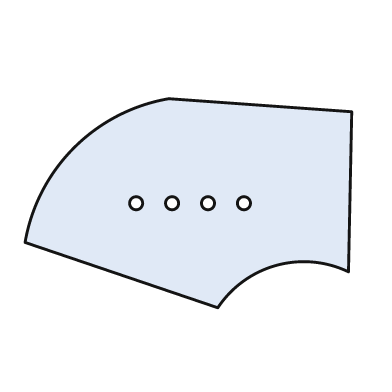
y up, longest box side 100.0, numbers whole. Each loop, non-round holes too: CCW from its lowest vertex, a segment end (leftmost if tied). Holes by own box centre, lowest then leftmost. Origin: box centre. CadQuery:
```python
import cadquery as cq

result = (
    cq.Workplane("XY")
    .moveTo(9.0, -32.0)
    .threePointArc((27.0, -19.0), (49.0, -21.0))
    .lineTo(50.0, 28.0)
    .lineTo(-6.0, 32.0)
    .threePointArc((-35.0, 17.0), (-50.0, -12.0))
    .close()
    .moveTo(-16.0, 0.0)
    .circle(2.0)
    .moveTo(-5.0, 0.0)
    .circle(2.0)
    .moveTo(6.0, 0.0)
    .circle(2.0)
    .moveTo(17.0, 0.0)
    .circle(2.0)
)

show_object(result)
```